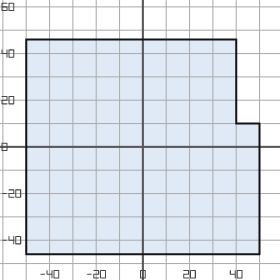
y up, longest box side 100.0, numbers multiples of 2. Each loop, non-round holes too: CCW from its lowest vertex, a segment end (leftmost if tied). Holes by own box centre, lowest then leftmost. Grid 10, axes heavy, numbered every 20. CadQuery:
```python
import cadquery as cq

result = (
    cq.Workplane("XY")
    .moveTo(-50.0, -46.0)
    .lineTo(50.0, -46.0)
    .lineTo(50.0, 10.0)
    .lineTo(40.0, 10.0)
    .lineTo(40.0, 46.0)
    .lineTo(-50.0, 46.0)
    .close()
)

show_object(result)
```